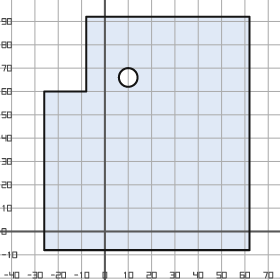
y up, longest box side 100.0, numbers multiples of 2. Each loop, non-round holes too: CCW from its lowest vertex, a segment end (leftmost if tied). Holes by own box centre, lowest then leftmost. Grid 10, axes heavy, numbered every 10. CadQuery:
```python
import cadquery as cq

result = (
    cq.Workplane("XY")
    .moveTo(-26.0, -8.0)
    .lineTo(62.0, -8.0)
    .lineTo(62.0, 92.0)
    .lineTo(-8.0, 92.0)
    .lineTo(-8.0, 60.0)
    .lineTo(-26.0, 60.0)
    .close()
    .moveTo(10.0, 66.0)
    .circle(4.0)
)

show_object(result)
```